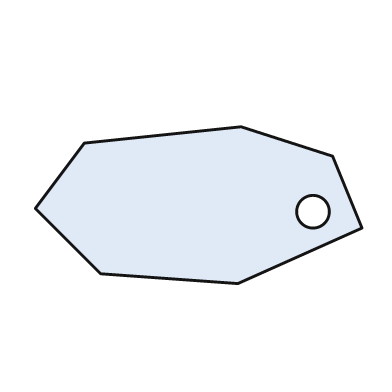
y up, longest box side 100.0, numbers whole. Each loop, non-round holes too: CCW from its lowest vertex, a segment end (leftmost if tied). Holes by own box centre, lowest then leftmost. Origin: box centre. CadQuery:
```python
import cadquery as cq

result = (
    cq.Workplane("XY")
    .moveTo(12.0, -24.0)
    .lineTo(50.0, -7.0)
    .lineTo(41.0, 15.0)
    .lineTo(13.0, 24.0)
    .lineTo(-35.0, 19.0)
    .lineTo(-50.0, -1.0)
    .lineTo(-30.0, -21.0)
    .close()
    .moveTo(35.0, -2.0)
    .circle(5.0)
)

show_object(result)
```